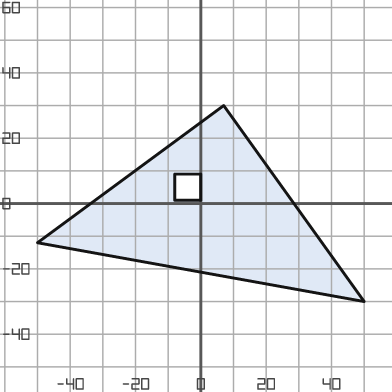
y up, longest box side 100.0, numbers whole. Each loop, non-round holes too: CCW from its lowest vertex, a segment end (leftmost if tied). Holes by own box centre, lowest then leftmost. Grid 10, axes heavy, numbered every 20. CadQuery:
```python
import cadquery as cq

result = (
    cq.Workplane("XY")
    .moveTo(50.0, -30.0)
    .lineTo(7.0, 30.0)
    .lineTo(-50.0, -12.0)
    .close()
    .moveTo(-8.0, 1.0)
    .lineTo(0.0, 1.0)
    .lineTo(0.0, 9.0)
    .lineTo(-8.0, 9.0)
    .close()
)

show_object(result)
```